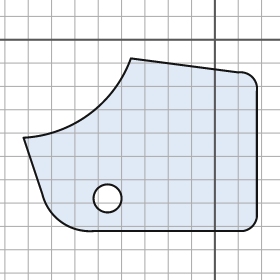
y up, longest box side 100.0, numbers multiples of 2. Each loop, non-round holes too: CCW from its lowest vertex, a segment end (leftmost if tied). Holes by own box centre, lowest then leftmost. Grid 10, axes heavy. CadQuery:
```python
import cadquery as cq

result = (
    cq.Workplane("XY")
    .moveTo(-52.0, -82.0)
    .lineTo(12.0, -82.0)
    .threePointArc((16.0, -80.0), (18.0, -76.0))
    .lineTo(18.0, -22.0)
    .threePointArc((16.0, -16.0), (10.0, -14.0))
    .lineTo(-36.0, -8.0)
    .threePointArc((-54.0, -32.0), (-82.0, -42.0))
    .lineTo(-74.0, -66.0)
    .threePointArc((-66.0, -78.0), (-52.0, -82.0))
    .close()
    .moveTo(-46.0, -68.0)
    .circle(6.0)
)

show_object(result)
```